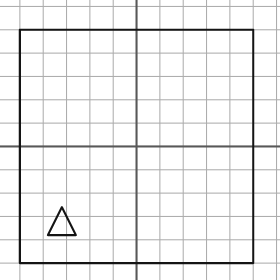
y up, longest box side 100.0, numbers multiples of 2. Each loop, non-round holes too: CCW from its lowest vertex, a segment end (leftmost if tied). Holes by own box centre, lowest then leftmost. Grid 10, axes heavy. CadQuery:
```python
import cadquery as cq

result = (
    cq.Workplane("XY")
    .moveTo(-50.0, -50.0)
    .lineTo(50.0, -50.0)
    .lineTo(50.0, 50.0)
    .lineTo(-50.0, 50.0)
    .close()
    .moveTo(-38.0, -38.0)
    .lineTo(-26.0, -38.0)
    .lineTo(-32.0, -26.0)
    .close()
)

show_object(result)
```